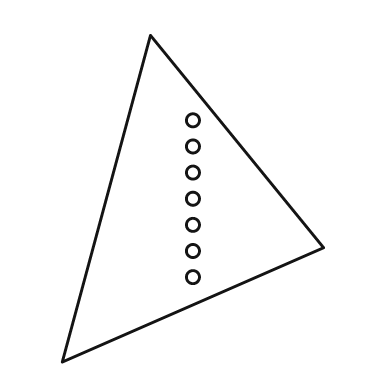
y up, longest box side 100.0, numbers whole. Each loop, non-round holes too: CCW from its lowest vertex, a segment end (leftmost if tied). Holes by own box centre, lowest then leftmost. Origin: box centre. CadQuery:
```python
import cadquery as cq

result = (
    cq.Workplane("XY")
    .moveTo(-40.0, -50.0)
    .lineTo(40.0, -15.0)
    .lineTo(-13.0, 50.0)
    .close()
    .moveTo(0.0, -24.0)
    .circle(2.0)
    .moveTo(0.0, -16.0)
    .circle(2.0)
    .moveTo(0.0, -8.0)
    .circle(2.0)
    .moveTo(0.0, 0.0)
    .circle(2.0)
    .moveTo(0.0, 8.0)
    .circle(2.0)
    .moveTo(0.0, 16.0)
    .circle(2.0)
    .moveTo(0.0, 24.0)
    .circle(2.0)
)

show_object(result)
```